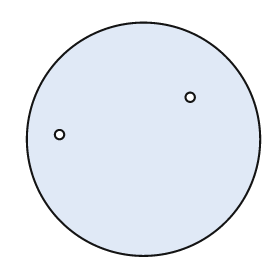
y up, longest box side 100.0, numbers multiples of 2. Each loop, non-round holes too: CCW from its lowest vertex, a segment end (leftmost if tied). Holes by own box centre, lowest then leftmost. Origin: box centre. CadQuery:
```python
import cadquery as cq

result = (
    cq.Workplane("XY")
    .moveTo(0.0, 0.0)
    .circle(50.0)
    .moveTo(-36.0, 2.0)
    .circle(2.0)
    .moveTo(20.0, 18.0)
    .circle(2.0)
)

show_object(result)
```